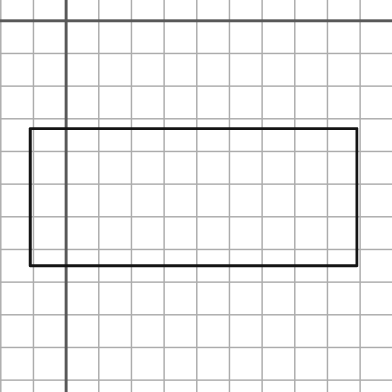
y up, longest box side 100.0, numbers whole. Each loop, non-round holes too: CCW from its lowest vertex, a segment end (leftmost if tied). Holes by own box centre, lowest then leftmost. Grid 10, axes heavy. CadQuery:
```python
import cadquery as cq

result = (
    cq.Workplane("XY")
    .moveTo(-11.0, -75.0)
    .lineTo(89.0, -75.0)
    .lineTo(89.0, -33.0)
    .lineTo(-11.0, -33.0)
    .close()
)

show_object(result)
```